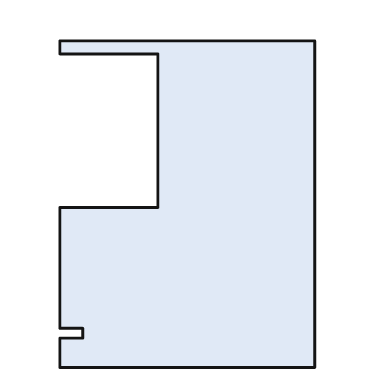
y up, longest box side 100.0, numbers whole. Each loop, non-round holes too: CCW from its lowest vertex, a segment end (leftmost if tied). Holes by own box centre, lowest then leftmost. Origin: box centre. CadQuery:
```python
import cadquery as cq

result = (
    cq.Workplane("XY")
    .moveTo(-39.0, -50.0)
    .lineTo(39.0, -50.0)
    .lineTo(39.0, 50.0)
    .lineTo(-39.0, 50.0)
    .lineTo(-39.0, 46.0)
    .lineTo(-9.0, 46.0)
    .lineTo(-9.0, -1.0)
    .lineTo(-39.0, -1.0)
    .lineTo(-39.0, -38.0)
    .lineTo(-32.0, -38.0)
    .lineTo(-32.0, -41.0)
    .lineTo(-39.0, -41.0)
    .close()
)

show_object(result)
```